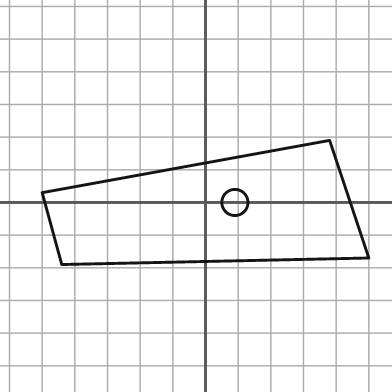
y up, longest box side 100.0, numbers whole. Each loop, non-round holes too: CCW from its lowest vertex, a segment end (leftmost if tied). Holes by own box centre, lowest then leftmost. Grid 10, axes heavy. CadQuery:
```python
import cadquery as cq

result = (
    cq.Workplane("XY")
    .moveTo(-44.0, -19.0)
    .lineTo(50.0, -17.0)
    .lineTo(38.0, 19.0)
    .lineTo(-50.0, 3.0)
    .close()
    .moveTo(9.0, 0.0)
    .circle(4.0)
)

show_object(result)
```